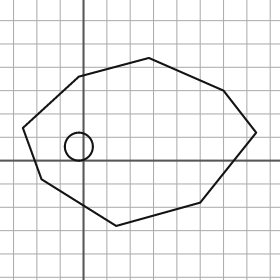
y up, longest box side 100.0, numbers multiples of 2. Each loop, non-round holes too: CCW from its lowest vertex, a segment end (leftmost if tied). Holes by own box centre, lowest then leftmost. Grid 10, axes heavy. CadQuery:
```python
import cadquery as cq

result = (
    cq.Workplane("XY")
    .moveTo(14.0, -28.0)
    .lineTo(50.0, -18.0)
    .lineTo(74.0, 12.0)
    .lineTo(60.0, 30.0)
    .lineTo(28.0, 44.0)
    .lineTo(-2.0, 36.0)
    .lineTo(-26.0, 14.0)
    .lineTo(-18.0, -8.0)
    .close()
    .moveTo(-2.0, 6.0)
    .circle(6.0)
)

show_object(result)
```